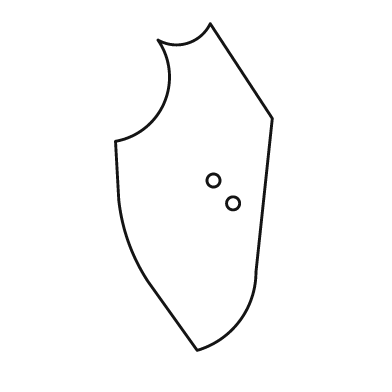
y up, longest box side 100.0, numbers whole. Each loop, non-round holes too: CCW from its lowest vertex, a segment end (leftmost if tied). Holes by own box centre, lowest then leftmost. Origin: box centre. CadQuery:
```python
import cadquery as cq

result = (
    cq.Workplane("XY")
    .moveTo(1.0, -50.0)
    .threePointArc((14.0, -41.0), (19.0, -26.0))
    .lineTo(24.0, 21.0)
    .lineTo(5.0, 50.0)
    .threePointArc((-2.0, 44.0), (-11.0, 45.0))
    .threePointArc((-9.0, 26.0), (-24.0, 14.0))
    .lineTo(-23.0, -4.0)
    .threePointArc((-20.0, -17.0), (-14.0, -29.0))
    .close()
    .moveTo(12.0, -5.0)
    .circle(2.0)
    .moveTo(6.0, 2.0)
    .circle(2.0)
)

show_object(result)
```